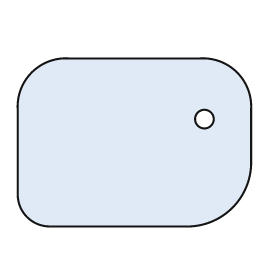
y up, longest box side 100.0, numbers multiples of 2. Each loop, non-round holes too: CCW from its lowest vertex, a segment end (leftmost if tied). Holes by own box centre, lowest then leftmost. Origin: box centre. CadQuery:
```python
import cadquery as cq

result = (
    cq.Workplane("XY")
    .moveTo(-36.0, -36.0)
    .lineTo(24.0, -36.0)
    .threePointArc((42.0, -28.0), (50.0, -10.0))
    .lineTo(50.0, 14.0)
    .threePointArc((44.0, 30.0), (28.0, 36.0))
    .lineTo(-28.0, 36.0)
    .threePointArc((-44.0, 30.0), (-50.0, 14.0))
    .lineTo(-50.0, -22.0)
    .threePointArc((-46.0, -32.0), (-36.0, -36.0))
    .close()
    .moveTo(30.0, 10.0)
    .circle(4.0)
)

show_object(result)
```